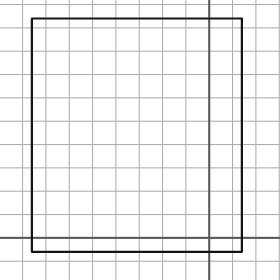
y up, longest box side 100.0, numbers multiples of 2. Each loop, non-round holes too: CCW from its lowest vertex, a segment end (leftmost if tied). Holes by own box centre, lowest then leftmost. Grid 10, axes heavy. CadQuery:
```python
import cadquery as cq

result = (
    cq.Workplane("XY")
    .moveTo(-76.0, -6.0)
    .lineTo(14.0, -6.0)
    .lineTo(14.0, 94.0)
    .lineTo(-76.0, 94.0)
    .close()
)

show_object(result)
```